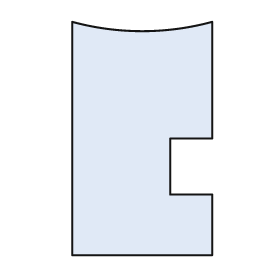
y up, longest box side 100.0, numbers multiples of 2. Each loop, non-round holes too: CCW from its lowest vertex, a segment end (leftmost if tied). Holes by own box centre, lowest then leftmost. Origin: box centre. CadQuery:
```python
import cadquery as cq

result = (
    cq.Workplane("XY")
    .moveTo(-30.0, -50.0)
    .lineTo(30.0, -50.0)
    .lineTo(30.0, -24.0)
    .lineTo(12.0, -24.0)
    .lineTo(12.0, 0.0)
    .lineTo(30.0, 0.0)
    .lineTo(30.0, 50.0)
    .threePointArc((0.0, 46.0), (-30.0, 50.0))
    .close()
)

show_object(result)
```